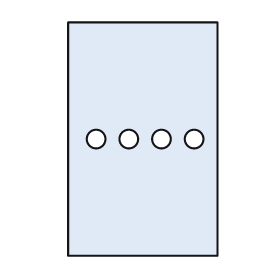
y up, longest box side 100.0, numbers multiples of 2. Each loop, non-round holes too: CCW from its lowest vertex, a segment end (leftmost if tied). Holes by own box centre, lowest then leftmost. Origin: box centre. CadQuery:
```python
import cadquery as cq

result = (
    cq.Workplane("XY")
    .moveTo(-32.0, -50.0)
    .lineTo(32.0, -50.0)
    .lineTo(32.0, 50.0)
    .lineTo(-32.0, 50.0)
    .close()
    .moveTo(-20.0, 0.0)
    .circle(4.0)
    .moveTo(-6.0, 0.0)
    .circle(4.0)
    .moveTo(8.0, 0.0)
    .circle(4.0)
    .moveTo(22.0, 0.0)
    .circle(4.0)
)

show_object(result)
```